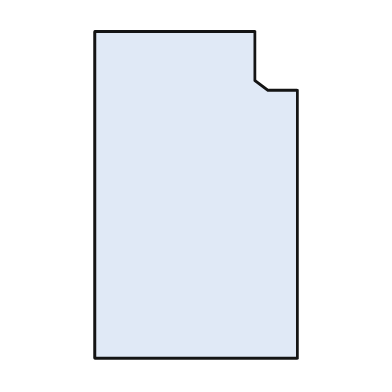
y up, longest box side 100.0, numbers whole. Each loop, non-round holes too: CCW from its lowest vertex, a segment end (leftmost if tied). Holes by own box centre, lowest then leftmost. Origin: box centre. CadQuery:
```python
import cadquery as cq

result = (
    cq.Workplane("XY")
    .moveTo(-31.0, -50.0)
    .lineTo(31.0, -50.0)
    .lineTo(31.0, 32.0)
    .lineTo(22.0, 32.0)
    .lineTo(18.0, 35.0)
    .lineTo(18.0, 50.0)
    .lineTo(-31.0, 50.0)
    .close()
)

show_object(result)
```